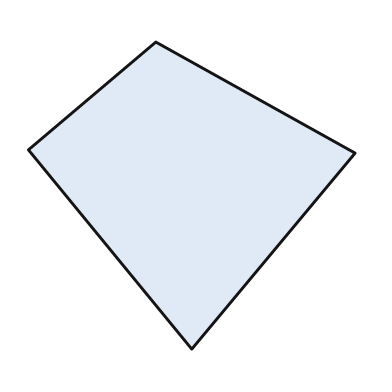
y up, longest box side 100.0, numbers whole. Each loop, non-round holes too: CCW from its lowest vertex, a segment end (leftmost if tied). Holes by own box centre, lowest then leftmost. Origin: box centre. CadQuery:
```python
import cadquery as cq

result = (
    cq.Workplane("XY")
    .moveTo(0.0, -47.0)
    .lineTo(50.0, 13.0)
    .lineTo(-11.0, 47.0)
    .lineTo(-50.0, 14.0)
    .close()
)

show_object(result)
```